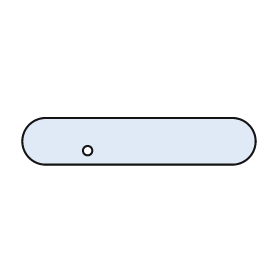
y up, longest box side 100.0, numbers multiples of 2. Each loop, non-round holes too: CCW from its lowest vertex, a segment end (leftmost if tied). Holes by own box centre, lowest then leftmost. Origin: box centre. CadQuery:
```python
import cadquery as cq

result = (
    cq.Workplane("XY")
    .moveTo(-40.0, -10.0)
    .lineTo(40.0, -10.0)
    .threePointArc((50.0, 0.0), (40.0, 10.0))
    .lineTo(-40.0, 10.0)
    .threePointArc((-50.0, 0.0), (-40.0, -10.0))
    .close()
    .moveTo(-22.0, -4.0)
    .circle(2.0)
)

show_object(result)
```